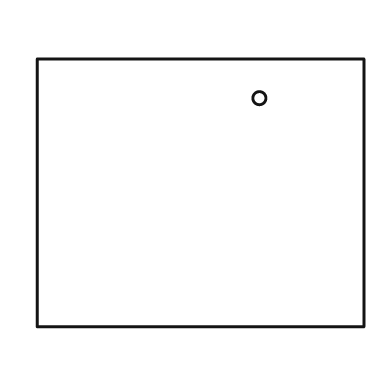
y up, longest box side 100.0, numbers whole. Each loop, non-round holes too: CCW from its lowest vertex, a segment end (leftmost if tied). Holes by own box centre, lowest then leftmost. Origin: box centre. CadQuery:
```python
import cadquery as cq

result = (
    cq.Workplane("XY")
    .moveTo(-50.0, -41.0)
    .lineTo(50.0, -41.0)
    .lineTo(50.0, 41.0)
    .lineTo(-50.0, 41.0)
    .close()
    .moveTo(18.0, 29.0)
    .circle(2.0)
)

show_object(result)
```